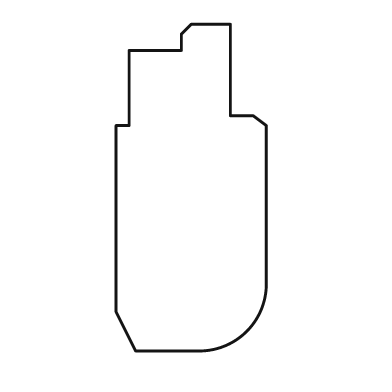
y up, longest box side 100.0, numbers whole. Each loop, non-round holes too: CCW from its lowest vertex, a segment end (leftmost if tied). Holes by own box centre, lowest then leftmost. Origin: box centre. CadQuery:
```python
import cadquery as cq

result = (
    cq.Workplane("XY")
    .moveTo(-17.0, -50.0)
    .lineTo(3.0, -50.0)
    .threePointArc((17.0, -44.0), (23.0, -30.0))
    .lineTo(23.0, 19.0)
    .lineTo(19.0, 22.0)
    .lineTo(12.0, 22.0)
    .lineTo(12.0, 50.0)
    .lineTo(0.0, 50.0)
    .lineTo(-3.0, 47.0)
    .lineTo(-3.0, 42.0)
    .lineTo(-19.0, 42.0)
    .lineTo(-19.0, 19.0)
    .lineTo(-23.0, 19.0)
    .lineTo(-23.0, -38.0)
    .close()
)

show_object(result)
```